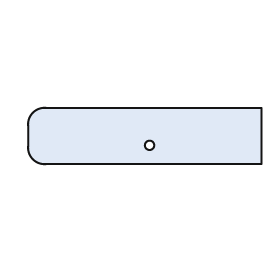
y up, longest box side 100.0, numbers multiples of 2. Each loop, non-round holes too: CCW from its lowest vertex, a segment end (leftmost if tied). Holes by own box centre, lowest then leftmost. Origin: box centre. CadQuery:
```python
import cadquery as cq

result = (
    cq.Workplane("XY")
    .moveTo(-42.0, -12.0)
    .lineTo(50.0, -12.0)
    .lineTo(50.0, 12.0)
    .lineTo(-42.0, 12.0)
    .threePointArc((-48.0, 10.0), (-50.0, 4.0))
    .lineTo(-50.0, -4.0)
    .threePointArc((-48.0, -10.0), (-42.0, -12.0))
    .close()
    .moveTo(2.0, -4.0)
    .circle(2.0)
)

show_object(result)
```